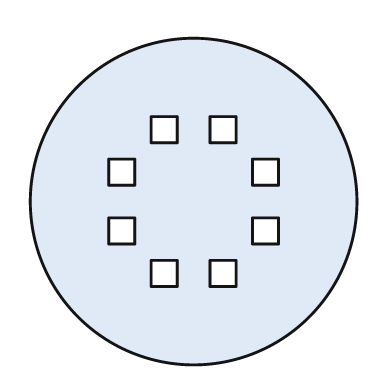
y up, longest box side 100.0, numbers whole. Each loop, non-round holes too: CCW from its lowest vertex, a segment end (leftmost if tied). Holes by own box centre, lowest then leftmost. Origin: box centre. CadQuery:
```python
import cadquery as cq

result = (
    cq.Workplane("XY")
    .moveTo(0.0, 0.0)
    .circle(50.0)
    .moveTo(-13.0, -26.0)
    .lineTo(-5.0, -26.0)
    .lineTo(-5.0, -18.0)
    .lineTo(-13.0, -18.0)
    .close()
    .moveTo(5.0, -26.0)
    .lineTo(13.0, -26.0)
    .lineTo(13.0, -18.0)
    .lineTo(5.0, -18.0)
    .close()
    .moveTo(-26.0, -13.0)
    .lineTo(-18.0, -13.0)
    .lineTo(-18.0, -5.0)
    .lineTo(-26.0, -5.0)
    .close()
    .moveTo(18.0, -13.0)
    .lineTo(26.0, -13.0)
    .lineTo(26.0, -5.0)
    .lineTo(18.0, -5.0)
    .close()
    .moveTo(-26.0, 5.0)
    .lineTo(-18.0, 5.0)
    .lineTo(-18.0, 13.0)
    .lineTo(-26.0, 13.0)
    .close()
    .moveTo(18.0, 5.0)
    .lineTo(26.0, 5.0)
    .lineTo(26.0, 13.0)
    .lineTo(18.0, 13.0)
    .close()
    .moveTo(-13.0, 18.0)
    .lineTo(-5.0, 18.0)
    .lineTo(-5.0, 26.0)
    .lineTo(-13.0, 26.0)
    .close()
    .moveTo(5.0, 18.0)
    .lineTo(13.0, 18.0)
    .lineTo(13.0, 26.0)
    .lineTo(5.0, 26.0)
    .close()
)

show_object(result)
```